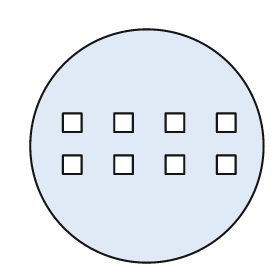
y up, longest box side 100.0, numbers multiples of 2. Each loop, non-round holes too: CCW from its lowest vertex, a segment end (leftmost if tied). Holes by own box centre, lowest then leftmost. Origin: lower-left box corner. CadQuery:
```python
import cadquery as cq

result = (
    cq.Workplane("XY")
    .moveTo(50.0, 50.0)
    .circle(50.0)
    .moveTo(14.0, 38.0)
    .lineTo(22.0, 38.0)
    .lineTo(22.0, 46.0)
    .lineTo(14.0, 46.0)
    .close()
    .moveTo(36.0, 38.0)
    .lineTo(44.0, 38.0)
    .lineTo(44.0, 46.0)
    .lineTo(36.0, 46.0)
    .close()
    .moveTo(58.0, 38.0)
    .lineTo(66.0, 38.0)
    .lineTo(66.0, 46.0)
    .lineTo(58.0, 46.0)
    .close()
    .moveTo(80.0, 38.0)
    .lineTo(88.0, 38.0)
    .lineTo(88.0, 46.0)
    .lineTo(80.0, 46.0)
    .close()
    .moveTo(14.0, 56.0)
    .lineTo(22.0, 56.0)
    .lineTo(22.0, 64.0)
    .lineTo(14.0, 64.0)
    .close()
    .moveTo(36.0, 56.0)
    .lineTo(44.0, 56.0)
    .lineTo(44.0, 64.0)
    .lineTo(36.0, 64.0)
    .close()
    .moveTo(58.0, 56.0)
    .lineTo(66.0, 56.0)
    .lineTo(66.0, 64.0)
    .lineTo(58.0, 64.0)
    .close()
    .moveTo(80.0, 56.0)
    .lineTo(88.0, 56.0)
    .lineTo(88.0, 64.0)
    .lineTo(80.0, 64.0)
    .close()
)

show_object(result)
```